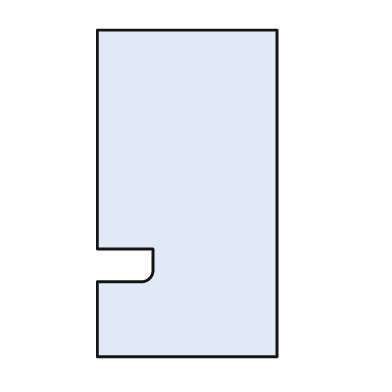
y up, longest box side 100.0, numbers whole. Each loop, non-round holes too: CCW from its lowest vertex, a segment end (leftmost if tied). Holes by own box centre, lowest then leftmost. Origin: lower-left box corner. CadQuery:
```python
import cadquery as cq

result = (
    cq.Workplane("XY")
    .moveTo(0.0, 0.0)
    .lineTo(55.0, 0.0)
    .lineTo(55.0, 100.0)
    .lineTo(0.0, 100.0)
    .lineTo(0.0, 33.0)
    .lineTo(17.0, 33.0)
    .lineTo(17.0, 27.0)
    .threePointArc((16.0, 24.0), (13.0, 23.0))
    .lineTo(0.0, 23.0)
    .close()
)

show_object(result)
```